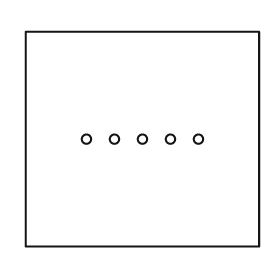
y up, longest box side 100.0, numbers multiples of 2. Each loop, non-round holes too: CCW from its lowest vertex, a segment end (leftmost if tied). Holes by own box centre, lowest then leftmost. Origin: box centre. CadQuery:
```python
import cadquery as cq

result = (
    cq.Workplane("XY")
    .moveTo(-50.0, -46.0)
    .lineTo(50.0, -46.0)
    .lineTo(50.0, 46.0)
    .lineTo(-50.0, 46.0)
    .close()
    .moveTo(-24.0, 0.0)
    .circle(2.0)
    .moveTo(-12.0, 0.0)
    .circle(2.0)
    .moveTo(0.0, 0.0)
    .circle(2.0)
    .moveTo(12.0, 0.0)
    .circle(2.0)
    .moveTo(24.0, 0.0)
    .circle(2.0)
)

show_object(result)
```